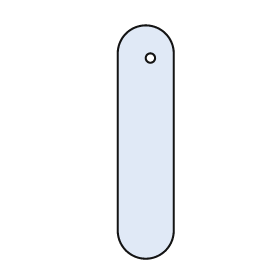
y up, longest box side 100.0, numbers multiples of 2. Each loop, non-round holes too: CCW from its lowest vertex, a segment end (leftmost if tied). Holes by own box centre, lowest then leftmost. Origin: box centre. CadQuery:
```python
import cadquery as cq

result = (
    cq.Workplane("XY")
    .moveTo(-12.0, -38.0)
    .threePointArc((0.0, -50.0), (12.0, -38.0))
    .lineTo(12.0, 38.0)
    .threePointArc((0.0, 50.0), (-12.0, 38.0))
    .close()
    .moveTo(2.0, 36.0)
    .circle(2.0)
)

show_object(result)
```